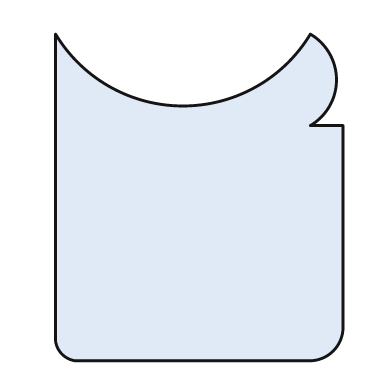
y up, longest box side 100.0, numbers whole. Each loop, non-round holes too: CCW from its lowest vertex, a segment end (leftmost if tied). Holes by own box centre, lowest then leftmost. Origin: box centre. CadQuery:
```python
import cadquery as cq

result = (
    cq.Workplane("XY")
    .moveTo(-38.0, -50.0)
    .lineTo(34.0, -50.0)
    .threePointArc((41.0, -47.0), (44.0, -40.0))
    .lineTo(44.0, 22.0)
    .lineTo(34.0, 22.0)
    .threePointArc((42.0, 36.0), (34.0, 50.0))
    .threePointArc((-5.0, 28.0), (-44.0, 50.0))
    .lineTo(-44.0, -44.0)
    .threePointArc((-42.0, -48.0), (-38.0, -50.0))
    .close()
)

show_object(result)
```